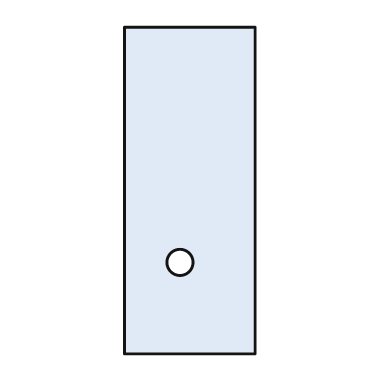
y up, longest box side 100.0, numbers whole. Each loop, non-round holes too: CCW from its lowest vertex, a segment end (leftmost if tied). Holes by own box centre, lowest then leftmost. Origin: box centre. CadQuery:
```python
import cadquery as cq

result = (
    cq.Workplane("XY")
    .moveTo(-20.0, -50.0)
    .lineTo(20.0, -50.0)
    .lineTo(20.0, 50.0)
    .lineTo(-20.0, 50.0)
    .close()
    .moveTo(-3.0, -22.0)
    .circle(4.0)
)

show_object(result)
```